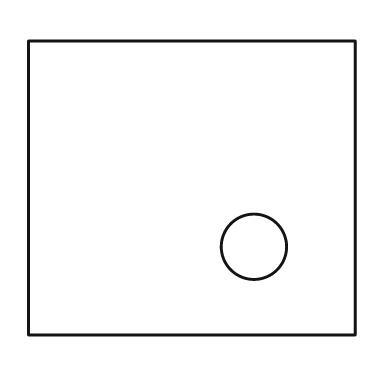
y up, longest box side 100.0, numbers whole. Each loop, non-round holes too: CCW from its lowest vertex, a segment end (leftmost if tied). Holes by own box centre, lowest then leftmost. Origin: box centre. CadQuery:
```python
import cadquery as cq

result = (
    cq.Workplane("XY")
    .moveTo(-50.0, -45.0)
    .lineTo(50.0, -45.0)
    .lineTo(50.0, 45.0)
    .lineTo(-50.0, 45.0)
    .close()
    .moveTo(19.0, -18.0)
    .circle(10.0)
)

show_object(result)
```